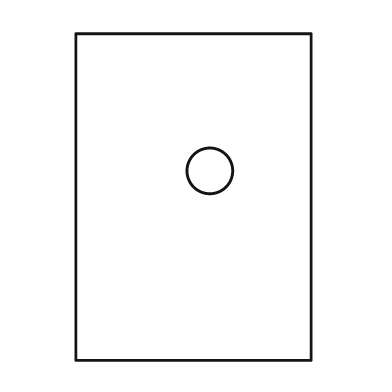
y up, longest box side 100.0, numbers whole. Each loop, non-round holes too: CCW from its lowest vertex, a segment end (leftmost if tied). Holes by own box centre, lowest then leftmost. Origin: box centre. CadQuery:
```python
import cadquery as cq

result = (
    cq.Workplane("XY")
    .moveTo(-36.0, -50.0)
    .lineTo(36.0, -50.0)
    .lineTo(36.0, 50.0)
    .lineTo(-36.0, 50.0)
    .close()
    .moveTo(5.0, 8.0)
    .circle(7.0)
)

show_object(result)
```